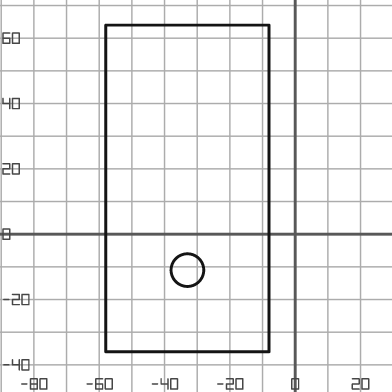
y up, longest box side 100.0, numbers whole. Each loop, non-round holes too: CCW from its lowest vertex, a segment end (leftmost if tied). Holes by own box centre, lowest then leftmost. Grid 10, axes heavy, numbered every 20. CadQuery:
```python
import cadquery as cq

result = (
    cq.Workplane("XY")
    .moveTo(-58.0, -36.0)
    .lineTo(-8.0, -36.0)
    .lineTo(-8.0, 64.0)
    .lineTo(-58.0, 64.0)
    .close()
    .moveTo(-33.0, -11.0)
    .circle(5.0)
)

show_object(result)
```